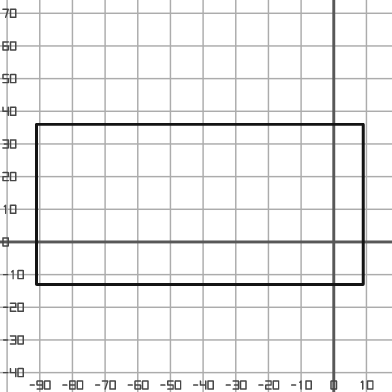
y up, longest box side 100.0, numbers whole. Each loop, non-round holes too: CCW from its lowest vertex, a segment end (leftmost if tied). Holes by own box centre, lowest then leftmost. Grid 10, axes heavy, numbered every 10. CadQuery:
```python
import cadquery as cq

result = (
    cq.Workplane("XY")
    .moveTo(-91.0, -13.0)
    .lineTo(9.0, -13.0)
    .lineTo(9.0, 36.0)
    .lineTo(-91.0, 36.0)
    .close()
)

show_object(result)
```